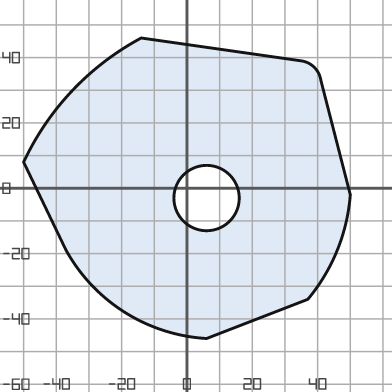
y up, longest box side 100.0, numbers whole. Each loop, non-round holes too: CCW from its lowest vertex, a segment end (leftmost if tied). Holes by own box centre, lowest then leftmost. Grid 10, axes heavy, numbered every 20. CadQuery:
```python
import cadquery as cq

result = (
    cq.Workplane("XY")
    .moveTo(6.0, -46.0)
    .lineTo(37.0, -34.0)
    .threePointArc((46.0, -19.0), (50.0, -2.0))
    .lineTo(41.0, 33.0)
    .threePointArc((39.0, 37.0), (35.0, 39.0))
    .lineTo(-14.0, 46.0)
    .threePointArc((-35.0, 30.0), (-50.0, 8.0))
    .lineTo(-37.0, -19.0)
    .threePointArc((-19.0, -38.0), (6.0, -46.0))
    .close()
    .moveTo(6.0, -3.0)
    .circle(10.0)
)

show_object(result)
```